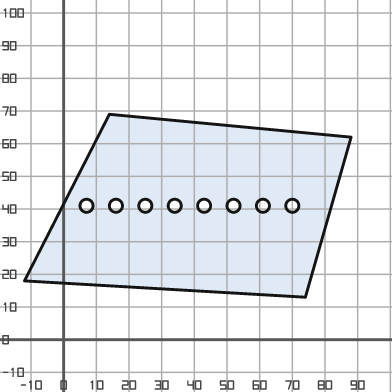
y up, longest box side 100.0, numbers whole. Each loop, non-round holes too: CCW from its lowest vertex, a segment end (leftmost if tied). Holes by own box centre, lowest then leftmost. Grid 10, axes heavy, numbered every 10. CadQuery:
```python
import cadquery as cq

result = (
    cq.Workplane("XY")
    .moveTo(74.0, 13.0)
    .lineTo(88.0, 62.0)
    .lineTo(14.0, 69.0)
    .lineTo(-12.0, 18.0)
    .close()
    .moveTo(7.0, 41.0)
    .circle(2.0)
    .moveTo(16.0, 41.0)
    .circle(2.0)
    .moveTo(25.0, 41.0)
    .circle(2.0)
    .moveTo(34.0, 41.0)
    .circle(2.0)
    .moveTo(43.0, 41.0)
    .circle(2.0)
    .moveTo(52.0, 41.0)
    .circle(2.0)
    .moveTo(61.0, 41.0)
    .circle(2.0)
    .moveTo(70.0, 41.0)
    .circle(2.0)
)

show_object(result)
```